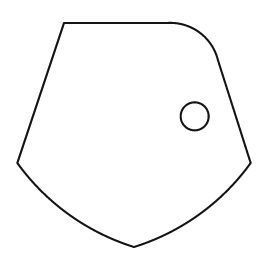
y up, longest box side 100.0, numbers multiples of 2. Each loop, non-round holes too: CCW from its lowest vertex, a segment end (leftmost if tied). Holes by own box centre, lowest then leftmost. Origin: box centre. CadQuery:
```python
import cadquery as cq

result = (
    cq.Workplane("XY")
    .moveTo(0.0, -48.0)
    .threePointArc((28.0, -34.0), (50.0, -12.0))
    .lineTo(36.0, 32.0)
    .threePointArc((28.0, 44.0), (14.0, 48.0))
    .lineTo(-30.0, 48.0)
    .lineTo(-50.0, -12.0)
    .threePointArc((-28.0, -34.0), (0.0, -48.0))
    .close()
    .moveTo(26.0, 8.0)
    .circle(6.0)
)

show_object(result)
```